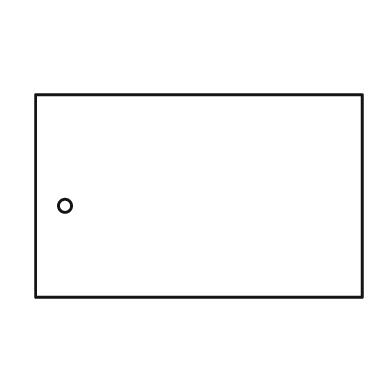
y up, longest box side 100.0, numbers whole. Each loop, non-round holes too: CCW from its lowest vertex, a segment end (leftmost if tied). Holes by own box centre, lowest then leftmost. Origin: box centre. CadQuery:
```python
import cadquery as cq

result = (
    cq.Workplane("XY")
    .moveTo(-50.0, -31.0)
    .lineTo(50.0, -31.0)
    .lineTo(50.0, 31.0)
    .lineTo(-50.0, 31.0)
    .close()
    .moveTo(-41.0, -3.0)
    .circle(2.0)
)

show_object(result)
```